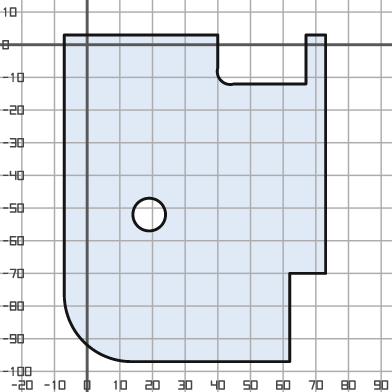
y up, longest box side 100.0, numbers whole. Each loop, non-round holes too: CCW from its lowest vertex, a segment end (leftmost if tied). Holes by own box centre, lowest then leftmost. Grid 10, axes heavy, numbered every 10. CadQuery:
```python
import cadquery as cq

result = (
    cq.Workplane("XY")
    .moveTo(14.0, -97.0)
    .lineTo(62.0, -97.0)
    .lineTo(62.0, -70.0)
    .lineTo(73.0, -70.0)
    .lineTo(73.0, 3.0)
    .lineTo(67.0, 3.0)
    .lineTo(67.0, -12.0)
    .lineTo(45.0, -12.0)
    .threePointArc((41.0, -11.0), (40.0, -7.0))
    .lineTo(40.0, 3.0)
    .lineTo(-7.0, 3.0)
    .lineTo(-7.0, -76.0)
    .threePointArc((-1.0, -91.0), (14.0, -97.0))
    .close()
    .moveTo(19.0, -52.0)
    .circle(5.0)
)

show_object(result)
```